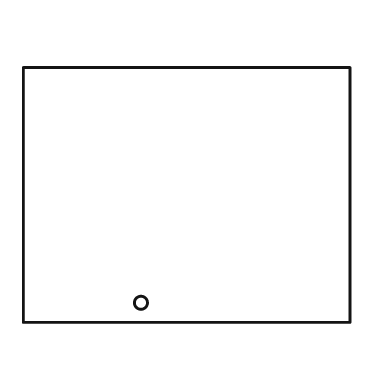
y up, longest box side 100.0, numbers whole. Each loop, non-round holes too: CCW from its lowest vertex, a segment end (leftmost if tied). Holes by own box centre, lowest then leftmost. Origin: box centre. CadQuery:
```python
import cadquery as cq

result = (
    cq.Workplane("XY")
    .moveTo(-50.0, -39.0)
    .lineTo(50.0, -39.0)
    .lineTo(50.0, 39.0)
    .lineTo(-50.0, 39.0)
    .close()
    .moveTo(-14.0, -33.0)
    .circle(2.0)
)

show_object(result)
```